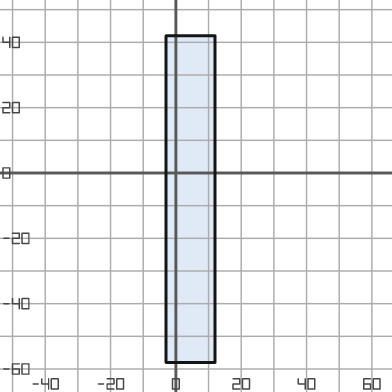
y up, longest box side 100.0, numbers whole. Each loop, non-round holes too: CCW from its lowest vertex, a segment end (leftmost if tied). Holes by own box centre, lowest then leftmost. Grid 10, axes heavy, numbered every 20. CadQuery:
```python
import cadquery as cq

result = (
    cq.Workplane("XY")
    .moveTo(-3.0, -58.0)
    .lineTo(12.0, -58.0)
    .lineTo(12.0, 42.0)
    .lineTo(-3.0, 42.0)
    .close()
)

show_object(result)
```